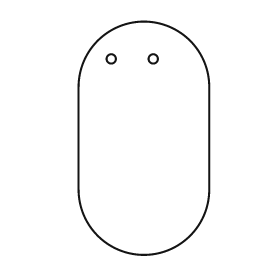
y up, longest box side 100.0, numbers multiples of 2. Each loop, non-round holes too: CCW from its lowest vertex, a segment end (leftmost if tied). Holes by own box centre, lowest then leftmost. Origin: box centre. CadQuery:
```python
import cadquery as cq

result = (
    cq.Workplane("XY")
    .moveTo(-28.0, -22.0)
    .threePointArc((0.0, -50.0), (28.0, -22.0))
    .lineTo(28.0, 22.0)
    .threePointArc((0.0, 50.0), (-28.0, 22.0))
    .close()
    .moveTo(-14.0, 34.0)
    .circle(2.0)
    .moveTo(4.0, 34.0)
    .circle(2.0)
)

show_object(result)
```